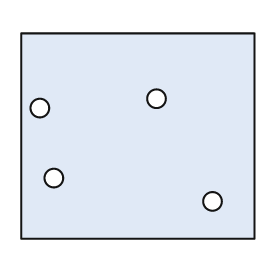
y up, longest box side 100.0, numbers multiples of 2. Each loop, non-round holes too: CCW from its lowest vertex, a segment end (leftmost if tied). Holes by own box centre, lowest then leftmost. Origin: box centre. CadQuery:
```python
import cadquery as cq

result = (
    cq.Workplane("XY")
    .moveTo(-50.0, -44.0)
    .lineTo(50.0, -44.0)
    .lineTo(50.0, 44.0)
    .lineTo(-50.0, 44.0)
    .close()
    .moveTo(32.0, -28.0)
    .circle(4.0)
    .moveTo(-36.0, -18.0)
    .circle(4.0)
    .moveTo(-42.0, 12.0)
    .circle(4.0)
    .moveTo(8.0, 16.0)
    .circle(4.0)
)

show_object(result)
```